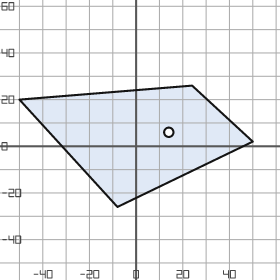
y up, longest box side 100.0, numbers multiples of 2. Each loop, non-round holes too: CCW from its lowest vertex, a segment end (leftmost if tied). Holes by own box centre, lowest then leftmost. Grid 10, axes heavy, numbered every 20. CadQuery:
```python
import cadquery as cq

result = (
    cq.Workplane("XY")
    .moveTo(-8.0, -26.0)
    .lineTo(50.0, 2.0)
    .lineTo(24.0, 26.0)
    .lineTo(-50.0, 20.0)
    .close()
    .moveTo(14.0, 6.0)
    .circle(2.0)
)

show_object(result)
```